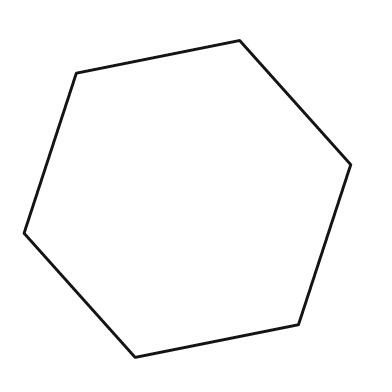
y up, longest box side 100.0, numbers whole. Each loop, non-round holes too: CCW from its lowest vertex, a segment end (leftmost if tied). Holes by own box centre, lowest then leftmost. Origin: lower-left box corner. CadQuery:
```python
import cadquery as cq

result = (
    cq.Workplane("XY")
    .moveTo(34.0, 0.0)
    .lineTo(84.0, 10.0)
    .lineTo(100.0, 59.0)
    .lineTo(66.0, 97.0)
    .lineTo(16.0, 87.0)
    .lineTo(0.0, 38.0)
    .close()
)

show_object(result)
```